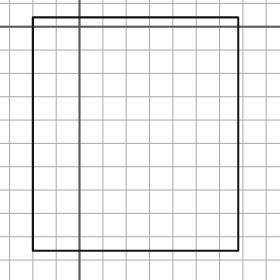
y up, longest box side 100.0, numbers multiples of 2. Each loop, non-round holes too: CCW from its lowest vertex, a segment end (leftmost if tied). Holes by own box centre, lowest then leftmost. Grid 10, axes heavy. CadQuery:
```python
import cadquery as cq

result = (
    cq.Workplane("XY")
    .moveTo(-20.0, -96.0)
    .lineTo(68.0, -96.0)
    .lineTo(68.0, 4.0)
    .lineTo(-20.0, 4.0)
    .close()
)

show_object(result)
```